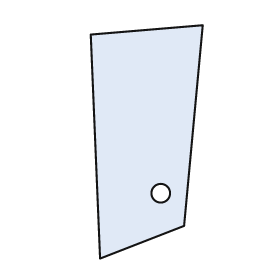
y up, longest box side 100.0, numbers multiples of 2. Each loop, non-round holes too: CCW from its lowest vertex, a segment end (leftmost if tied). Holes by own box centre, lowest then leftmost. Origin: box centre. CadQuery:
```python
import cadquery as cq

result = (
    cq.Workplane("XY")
    .moveTo(-20.0, -50.0)
    .lineTo(16.0, -36.0)
    .lineTo(24.0, 50.0)
    .lineTo(-24.0, 46.0)
    .close()
    .moveTo(6.0, -22.0)
    .circle(4.0)
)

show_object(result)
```